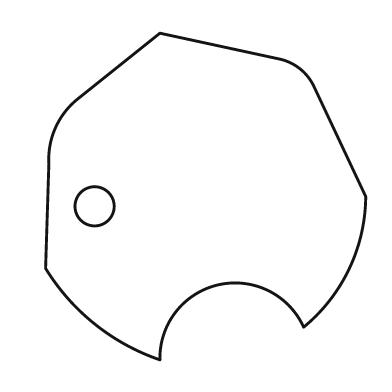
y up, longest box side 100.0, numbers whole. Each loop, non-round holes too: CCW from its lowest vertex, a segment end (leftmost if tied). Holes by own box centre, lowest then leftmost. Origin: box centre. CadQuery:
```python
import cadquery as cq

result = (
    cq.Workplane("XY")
    .moveTo(-14.0, -50.0)
    .threePointArc((4.0, -27.0), (30.0, -40.0))
    .threePointArc((44.0, -22.0), (49.0, 0.0))
    .lineTo(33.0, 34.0)
    .threePointArc((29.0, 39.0), (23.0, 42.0))
    .lineTo(-14.0, 50.0)
    .lineTo(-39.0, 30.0)
    .threePointArc((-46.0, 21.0), (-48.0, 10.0))
    .lineTo(-49.0, -22.0)
    .threePointArc((-34.0, -39.0), (-14.0, -50.0))
    .close()
    .moveTo(-34.0, -3.0)
    .circle(6.0)
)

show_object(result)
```